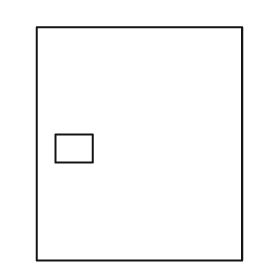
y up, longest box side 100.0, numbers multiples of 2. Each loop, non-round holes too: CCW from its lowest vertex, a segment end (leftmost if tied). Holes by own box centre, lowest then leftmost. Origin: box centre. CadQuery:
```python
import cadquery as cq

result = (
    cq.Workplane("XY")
    .moveTo(-44.0, -50.0)
    .lineTo(44.0, -50.0)
    .lineTo(44.0, 50.0)
    .lineTo(-44.0, 50.0)
    .close()
    .moveTo(-36.0, -8.0)
    .lineTo(-20.0, -8.0)
    .lineTo(-20.0, 4.0)
    .lineTo(-36.0, 4.0)
    .close()
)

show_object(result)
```